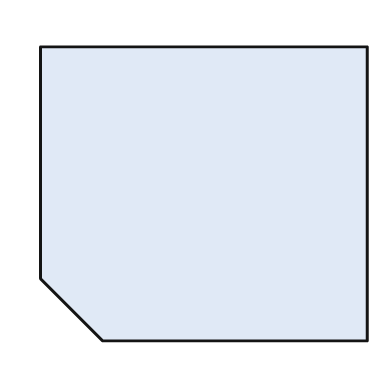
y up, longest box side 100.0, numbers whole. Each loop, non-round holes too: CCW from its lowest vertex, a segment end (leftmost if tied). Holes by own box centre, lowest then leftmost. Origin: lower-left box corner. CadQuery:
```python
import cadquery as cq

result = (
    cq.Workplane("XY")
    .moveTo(19.0, 0.0)
    .lineTo(100.0, 0.0)
    .lineTo(100.0, 90.0)
    .lineTo(0.0, 90.0)
    .lineTo(0.0, 19.0)
    .close()
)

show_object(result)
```